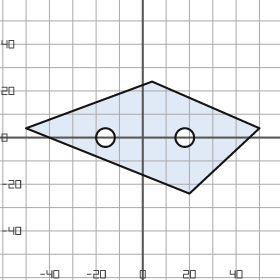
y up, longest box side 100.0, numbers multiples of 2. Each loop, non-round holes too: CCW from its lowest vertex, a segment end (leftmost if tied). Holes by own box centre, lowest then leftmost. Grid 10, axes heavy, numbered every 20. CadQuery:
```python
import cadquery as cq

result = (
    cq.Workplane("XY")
    .moveTo(20.0, -24.0)
    .lineTo(50.0, 4.0)
    .lineTo(4.0, 24.0)
    .lineTo(-50.0, 4.0)
    .close()
    .moveTo(-16.0, 0.0)
    .circle(4.0)
    .moveTo(18.0, 0.0)
    .circle(4.0)
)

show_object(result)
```